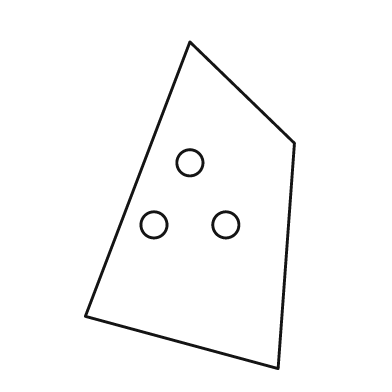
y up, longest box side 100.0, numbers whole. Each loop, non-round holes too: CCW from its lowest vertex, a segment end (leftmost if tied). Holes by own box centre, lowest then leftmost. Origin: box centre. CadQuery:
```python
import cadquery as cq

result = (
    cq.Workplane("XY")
    .moveTo(27.0, -50.0)
    .lineTo(32.0, 19.0)
    .lineTo(0.0, 50.0)
    .lineTo(-32.0, -34.0)
    .close()
    .moveTo(-11.0, -6.0)
    .circle(4.0)
    .moveTo(11.0, -6.0)
    .circle(4.0)
    .moveTo(0.0, 13.0)
    .circle(4.0)
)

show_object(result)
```